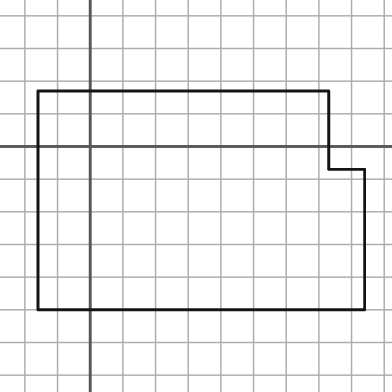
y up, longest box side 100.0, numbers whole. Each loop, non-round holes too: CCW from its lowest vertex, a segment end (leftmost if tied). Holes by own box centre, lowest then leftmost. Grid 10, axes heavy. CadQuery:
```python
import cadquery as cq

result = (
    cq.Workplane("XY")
    .moveTo(-16.0, -50.0)
    .lineTo(84.0, -50.0)
    .lineTo(84.0, -7.0)
    .lineTo(73.0, -7.0)
    .lineTo(73.0, 17.0)
    .lineTo(-16.0, 17.0)
    .close()
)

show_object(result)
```